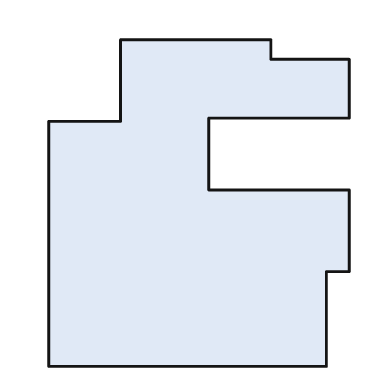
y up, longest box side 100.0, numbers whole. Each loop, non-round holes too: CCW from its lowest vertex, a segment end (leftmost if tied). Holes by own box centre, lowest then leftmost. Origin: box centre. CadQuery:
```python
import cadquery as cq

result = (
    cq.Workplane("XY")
    .moveTo(-46.0, -50.0)
    .lineTo(39.0, -50.0)
    .lineTo(39.0, -21.0)
    .lineTo(46.0, -21.0)
    .lineTo(46.0, 4.0)
    .lineTo(3.0, 4.0)
    .lineTo(3.0, 26.0)
    .lineTo(46.0, 26.0)
    .lineTo(46.0, 44.0)
    .lineTo(22.0, 44.0)
    .lineTo(22.0, 50.0)
    .lineTo(-24.0, 50.0)
    .lineTo(-24.0, 25.0)
    .lineTo(-46.0, 25.0)
    .close()
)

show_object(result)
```